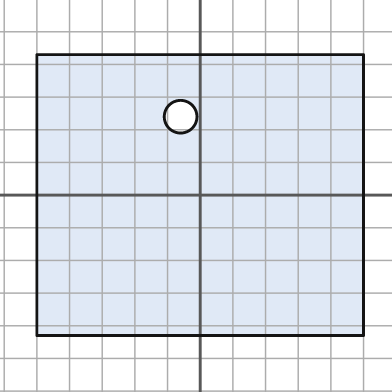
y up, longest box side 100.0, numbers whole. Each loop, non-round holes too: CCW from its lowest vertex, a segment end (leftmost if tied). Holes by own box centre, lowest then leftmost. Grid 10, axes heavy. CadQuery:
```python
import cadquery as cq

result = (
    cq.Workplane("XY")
    .moveTo(-50.0, -43.0)
    .lineTo(50.0, -43.0)
    .lineTo(50.0, 43.0)
    .lineTo(-50.0, 43.0)
    .close()
    .moveTo(-6.0, 24.0)
    .circle(5.0)
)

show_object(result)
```